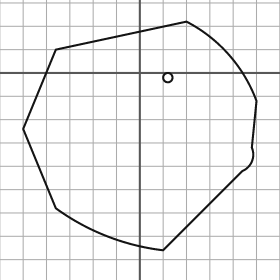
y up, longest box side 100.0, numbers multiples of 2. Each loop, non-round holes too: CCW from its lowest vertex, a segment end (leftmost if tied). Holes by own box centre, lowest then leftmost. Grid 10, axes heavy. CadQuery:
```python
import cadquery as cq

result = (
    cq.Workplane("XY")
    .moveTo(10.0, -76.0)
    .lineTo(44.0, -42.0)
    .threePointArc((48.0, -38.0), (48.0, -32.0))
    .lineTo(50.0, -12.0)
    .threePointArc((38.0, 8.0), (20.0, 22.0))
    .lineTo(-36.0, 10.0)
    .lineTo(-50.0, -24.0)
    .lineTo(-36.0, -58.0)
    .threePointArc((-14.0, -70.0), (10.0, -76.0))
    .close()
    .moveTo(12.0, -2.0)
    .circle(2.0)
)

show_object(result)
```